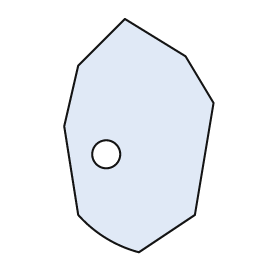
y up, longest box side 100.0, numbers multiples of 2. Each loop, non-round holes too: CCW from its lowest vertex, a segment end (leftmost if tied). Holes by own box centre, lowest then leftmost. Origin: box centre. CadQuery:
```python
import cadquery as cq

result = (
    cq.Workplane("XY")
    .moveTo(0.0, -50.0)
    .lineTo(24.0, -34.0)
    .lineTo(32.0, 14.0)
    .lineTo(20.0, 34.0)
    .lineTo(-6.0, 50.0)
    .lineTo(-26.0, 30.0)
    .lineTo(-32.0, 4.0)
    .lineTo(-26.0, -34.0)
    .threePointArc((-14.0, -44.0), (0.0, -50.0))
    .close()
    .moveTo(-14.0, -8.0)
    .circle(6.0)
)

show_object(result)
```